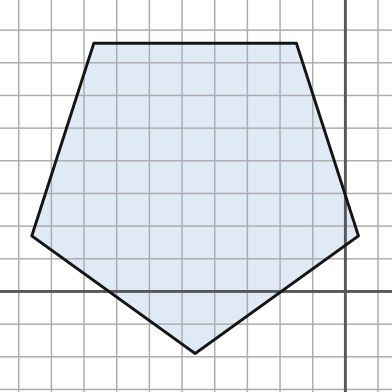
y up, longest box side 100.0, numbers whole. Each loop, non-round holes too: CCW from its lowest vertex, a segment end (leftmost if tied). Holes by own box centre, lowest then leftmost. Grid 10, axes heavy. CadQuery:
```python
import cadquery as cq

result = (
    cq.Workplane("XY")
    .moveTo(-46.0, -19.0)
    .lineTo(4.0, 17.0)
    .lineTo(-15.0, 76.0)
    .lineTo(-77.0, 76.0)
    .lineTo(-96.0, 17.0)
    .close()
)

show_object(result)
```